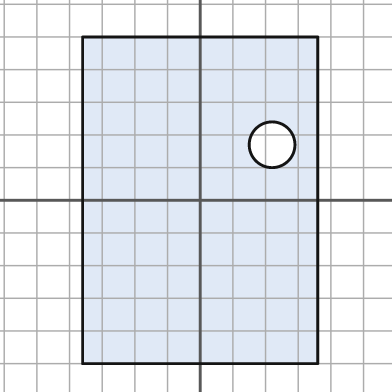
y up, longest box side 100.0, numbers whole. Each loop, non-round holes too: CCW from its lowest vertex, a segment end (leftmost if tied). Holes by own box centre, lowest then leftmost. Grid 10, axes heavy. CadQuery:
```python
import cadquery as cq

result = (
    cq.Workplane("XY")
    .moveTo(-36.0, -50.0)
    .lineTo(36.0, -50.0)
    .lineTo(36.0, 50.0)
    .lineTo(-36.0, 50.0)
    .close()
    .moveTo(22.0, 17.0)
    .circle(7.0)
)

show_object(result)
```